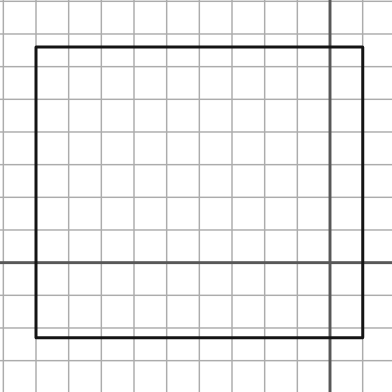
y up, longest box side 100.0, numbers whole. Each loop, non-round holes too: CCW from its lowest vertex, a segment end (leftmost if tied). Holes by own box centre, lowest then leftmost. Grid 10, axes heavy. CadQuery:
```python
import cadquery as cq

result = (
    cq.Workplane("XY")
    .moveTo(-90.0, -23.0)
    .lineTo(10.0, -23.0)
    .lineTo(10.0, 66.0)
    .lineTo(-90.0, 66.0)
    .close()
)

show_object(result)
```